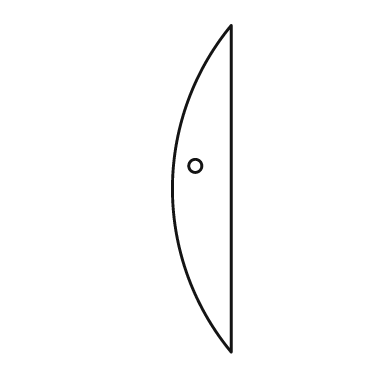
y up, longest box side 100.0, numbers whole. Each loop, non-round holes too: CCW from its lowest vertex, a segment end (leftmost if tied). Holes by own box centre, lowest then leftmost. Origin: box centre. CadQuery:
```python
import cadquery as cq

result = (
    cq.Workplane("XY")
    .moveTo(9.0, -50.0)
    .lineTo(9.0, 50.0)
    .threePointArc((-9.0, 0.0), (9.0, -50.0))
    .close()
    .moveTo(-2.0, 7.0)
    .circle(2.0)
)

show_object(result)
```